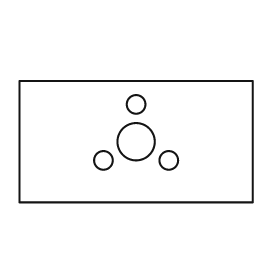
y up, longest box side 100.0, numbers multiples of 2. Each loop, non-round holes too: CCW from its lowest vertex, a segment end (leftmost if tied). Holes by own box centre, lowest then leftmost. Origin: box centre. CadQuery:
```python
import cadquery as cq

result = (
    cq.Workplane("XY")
    .moveTo(-50.0, -26.0)
    .lineTo(50.0, -26.0)
    .lineTo(50.0, 26.0)
    .lineTo(-50.0, 26.0)
    .close()
    .moveTo(-14.0, -8.0)
    .circle(4.0)
    .moveTo(14.0, -8.0)
    .circle(4.0)
    .moveTo(0.0, 0.0)
    .circle(8.0)
    .moveTo(0.0, 16.0)
    .circle(4.0)
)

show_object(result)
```